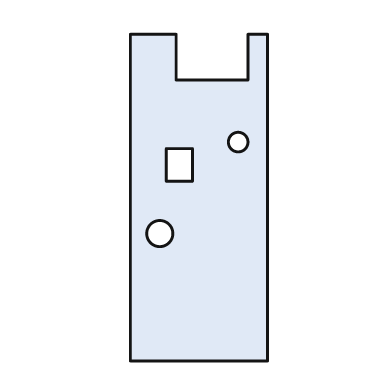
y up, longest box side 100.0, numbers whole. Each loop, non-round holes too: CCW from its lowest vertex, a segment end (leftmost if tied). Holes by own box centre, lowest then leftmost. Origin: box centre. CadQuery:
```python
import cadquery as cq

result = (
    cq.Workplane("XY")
    .moveTo(-21.0, -50.0)
    .lineTo(21.0, -50.0)
    .lineTo(21.0, 50.0)
    .lineTo(15.0, 50.0)
    .lineTo(15.0, 36.0)
    .lineTo(-7.0, 36.0)
    .lineTo(-7.0, 50.0)
    .lineTo(-21.0, 50.0)
    .close()
    .moveTo(-12.0, -11.0)
    .circle(4.0)
    .moveTo(-10.0, 5.0)
    .lineTo(-2.0, 5.0)
    .lineTo(-2.0, 15.0)
    .lineTo(-10.0, 15.0)
    .close()
    .moveTo(12.0, 17.0)
    .circle(3.0)
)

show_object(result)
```